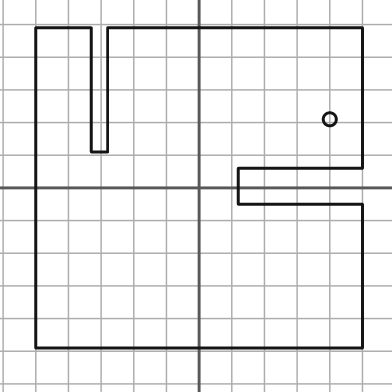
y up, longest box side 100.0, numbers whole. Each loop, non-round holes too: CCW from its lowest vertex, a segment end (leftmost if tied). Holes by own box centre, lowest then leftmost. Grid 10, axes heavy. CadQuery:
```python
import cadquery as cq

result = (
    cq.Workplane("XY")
    .moveTo(-50.0, -49.0)
    .lineTo(50.0, -49.0)
    .lineTo(50.0, -5.0)
    .lineTo(12.0, -5.0)
    .lineTo(12.0, 6.0)
    .lineTo(50.0, 6.0)
    .lineTo(50.0, 49.0)
    .lineTo(-28.0, 49.0)
    .lineTo(-28.0, 11.0)
    .lineTo(-33.0, 11.0)
    .lineTo(-33.0, 49.0)
    .lineTo(-50.0, 49.0)
    .close()
    .moveTo(40.0, 21.0)
    .circle(2.0)
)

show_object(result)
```